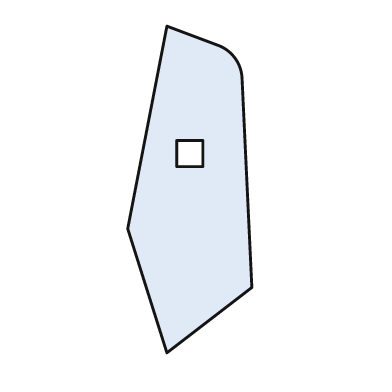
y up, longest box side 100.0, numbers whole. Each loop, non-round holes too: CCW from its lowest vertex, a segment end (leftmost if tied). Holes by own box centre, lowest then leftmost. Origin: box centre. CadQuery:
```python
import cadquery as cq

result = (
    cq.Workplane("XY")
    .moveTo(-7.0, -50.0)
    .lineTo(19.0, -30.0)
    .lineTo(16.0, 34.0)
    .threePointArc((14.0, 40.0), (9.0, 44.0))
    .lineTo(-7.0, 50.0)
    .lineTo(-19.0, -12.0)
    .close()
    .moveTo(-4.0, 7.0)
    .lineTo(4.0, 7.0)
    .lineTo(4.0, 15.0)
    .lineTo(-4.0, 15.0)
    .close()
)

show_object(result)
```